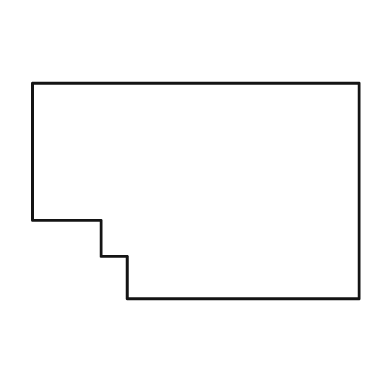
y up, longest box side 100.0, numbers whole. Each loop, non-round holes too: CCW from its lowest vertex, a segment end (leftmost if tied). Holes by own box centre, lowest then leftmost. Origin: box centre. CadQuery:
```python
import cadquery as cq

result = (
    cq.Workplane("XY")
    .moveTo(-21.0, -33.0)
    .lineTo(50.0, -33.0)
    .lineTo(50.0, 33.0)
    .lineTo(-50.0, 33.0)
    .lineTo(-50.0, -9.0)
    .lineTo(-29.0, -9.0)
    .lineTo(-29.0, -20.0)
    .lineTo(-21.0, -20.0)
    .close()
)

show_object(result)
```